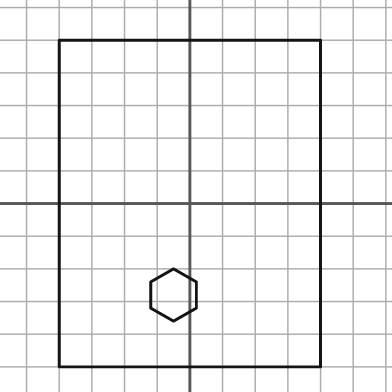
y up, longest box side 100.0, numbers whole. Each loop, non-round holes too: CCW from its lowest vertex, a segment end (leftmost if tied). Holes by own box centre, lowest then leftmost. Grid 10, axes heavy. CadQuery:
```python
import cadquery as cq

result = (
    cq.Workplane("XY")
    .moveTo(-40.0, -50.0)
    .lineTo(40.0, -50.0)
    .lineTo(40.0, 50.0)
    .lineTo(-40.0, 50.0)
    .close()
    .moveTo(-5.0, -36.0)
    .lineTo(2.0, -32.0)
    .lineTo(2.0, -24.0)
    .lineTo(-5.0, -20.0)
    .lineTo(-12.0, -24.0)
    .lineTo(-12.0, -32.0)
    .close()
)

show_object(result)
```